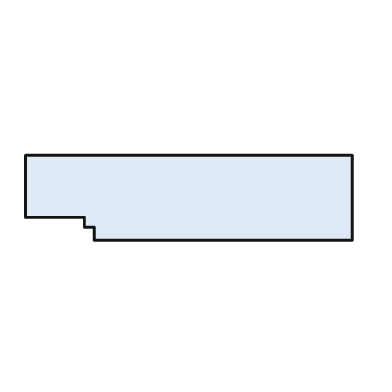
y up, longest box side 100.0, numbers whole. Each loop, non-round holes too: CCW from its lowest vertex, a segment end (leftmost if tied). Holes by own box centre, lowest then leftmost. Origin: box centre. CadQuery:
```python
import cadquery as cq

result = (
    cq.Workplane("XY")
    .moveTo(-29.0, -13.0)
    .lineTo(50.0, -13.0)
    .lineTo(50.0, 13.0)
    .lineTo(-50.0, 13.0)
    .lineTo(-50.0, -6.0)
    .lineTo(-32.0, -6.0)
    .lineTo(-32.0, -9.0)
    .lineTo(-29.0, -9.0)
    .close()
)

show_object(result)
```